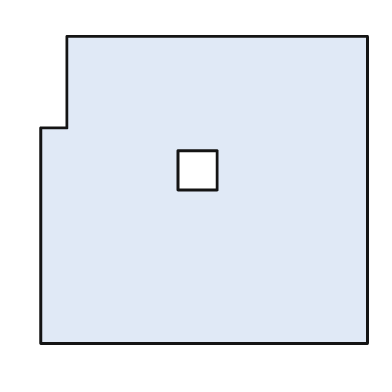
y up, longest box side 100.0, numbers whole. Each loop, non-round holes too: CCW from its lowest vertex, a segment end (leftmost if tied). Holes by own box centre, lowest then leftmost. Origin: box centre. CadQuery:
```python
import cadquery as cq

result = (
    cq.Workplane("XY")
    .moveTo(-50.0, -47.0)
    .lineTo(50.0, -47.0)
    .lineTo(50.0, 47.0)
    .lineTo(-42.0, 47.0)
    .lineTo(-42.0, 19.0)
    .lineTo(-50.0, 19.0)
    .close()
    .moveTo(-8.0, 0.0)
    .lineTo(4.0, 0.0)
    .lineTo(4.0, 12.0)
    .lineTo(-8.0, 12.0)
    .close()
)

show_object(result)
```